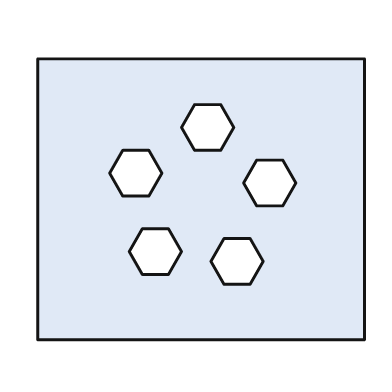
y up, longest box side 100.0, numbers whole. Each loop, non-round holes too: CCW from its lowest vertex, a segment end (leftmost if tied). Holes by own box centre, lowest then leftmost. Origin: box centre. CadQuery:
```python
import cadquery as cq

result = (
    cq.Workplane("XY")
    .moveTo(-50.0, -43.0)
    .lineTo(50.0, -43.0)
    .lineTo(50.0, 43.0)
    .lineTo(-50.0, 43.0)
    .close()
    .moveTo(7.0, -26.0)
    .lineTo(15.0, -26.0)
    .lineTo(19.0, -19.0)
    .lineTo(15.0, -12.0)
    .lineTo(7.0, -12.0)
    .lineTo(3.0, -19.0)
    .close()
    .moveTo(-18.0, -23.0)
    .lineTo(-10.0, -23.0)
    .lineTo(-6.0, -16.0)
    .lineTo(-10.0, -9.0)
    .lineTo(-18.0, -9.0)
    .lineTo(-22.0, -16.0)
    .close()
    .moveTo(17.0, -2.0)
    .lineTo(25.0, -2.0)
    .lineTo(29.0, 5.0)
    .lineTo(25.0, 12.0)
    .lineTo(17.0, 12.0)
    .lineTo(13.0, 5.0)
    .close()
    .moveTo(-24.0, 1.0)
    .lineTo(-16.0, 1.0)
    .lineTo(-12.0, 8.0)
    .lineTo(-16.0, 15.0)
    .lineTo(-24.0, 15.0)
    .lineTo(-28.0, 8.0)
    .close()
    .moveTo(-2.0, 15.0)
    .lineTo(6.0, 15.0)
    .lineTo(10.0, 22.0)
    .lineTo(6.0, 29.0)
    .lineTo(-2.0, 29.0)
    .lineTo(-6.0, 22.0)
    .close()
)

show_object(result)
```